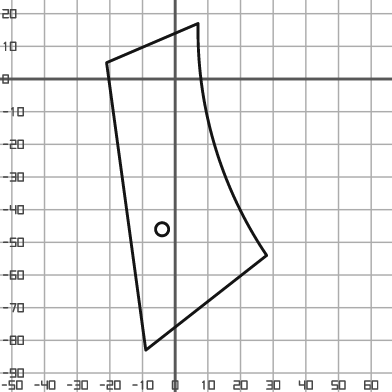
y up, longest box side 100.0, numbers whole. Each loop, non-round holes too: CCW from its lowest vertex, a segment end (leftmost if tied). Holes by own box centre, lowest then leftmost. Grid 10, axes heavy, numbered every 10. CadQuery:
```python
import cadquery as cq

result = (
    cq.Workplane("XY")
    .moveTo(-9.0, -83.0)
    .lineTo(28.0, -54.0)
    .threePointArc((12.0, -20.0), (7.0, 17.0))
    .lineTo(-21.0, 5.0)
    .close()
    .moveTo(-4.0, -46.0)
    .circle(2.0)
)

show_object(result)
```